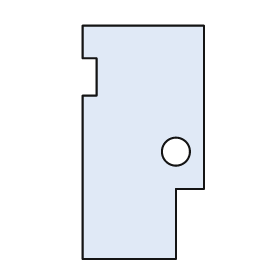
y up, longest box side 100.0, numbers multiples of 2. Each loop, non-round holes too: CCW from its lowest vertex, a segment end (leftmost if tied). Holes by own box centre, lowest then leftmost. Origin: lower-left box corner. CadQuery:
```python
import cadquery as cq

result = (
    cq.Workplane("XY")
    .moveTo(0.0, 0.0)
    .lineTo(40.0, 0.0)
    .lineTo(40.0, 30.0)
    .lineTo(52.0, 30.0)
    .lineTo(52.0, 100.0)
    .lineTo(0.0, 100.0)
    .lineTo(0.0, 86.0)
    .lineTo(6.0, 86.0)
    .lineTo(6.0, 70.0)
    .lineTo(0.0, 70.0)
    .close()
    .moveTo(40.0, 46.0)
    .circle(6.0)
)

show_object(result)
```